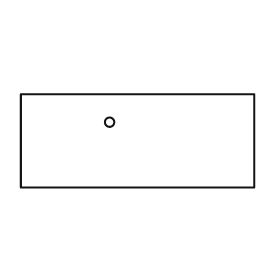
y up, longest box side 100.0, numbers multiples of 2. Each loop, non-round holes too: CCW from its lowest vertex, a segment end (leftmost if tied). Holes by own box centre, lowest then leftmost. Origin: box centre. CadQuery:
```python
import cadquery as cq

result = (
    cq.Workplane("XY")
    .moveTo(-50.0, -20.0)
    .lineTo(50.0, -20.0)
    .lineTo(50.0, 20.0)
    .lineTo(-50.0, 20.0)
    .close()
    .moveTo(-12.0, 8.0)
    .circle(2.0)
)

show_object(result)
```